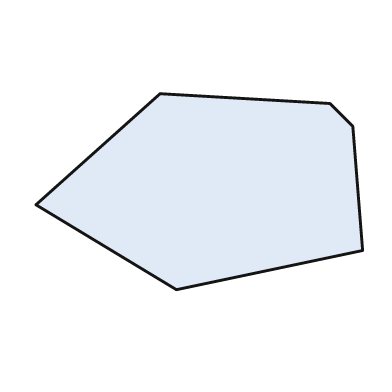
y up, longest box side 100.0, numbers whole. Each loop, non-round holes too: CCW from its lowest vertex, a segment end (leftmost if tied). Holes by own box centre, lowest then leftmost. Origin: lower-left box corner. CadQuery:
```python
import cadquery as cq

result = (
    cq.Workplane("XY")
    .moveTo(43.0, 0.0)
    .lineTo(100.0, 12.0)
    .lineTo(97.0, 50.0)
    .lineTo(90.0, 57.0)
    .lineTo(38.0, 60.0)
    .lineTo(0.0, 26.0)
    .close()
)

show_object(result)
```